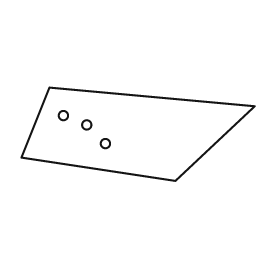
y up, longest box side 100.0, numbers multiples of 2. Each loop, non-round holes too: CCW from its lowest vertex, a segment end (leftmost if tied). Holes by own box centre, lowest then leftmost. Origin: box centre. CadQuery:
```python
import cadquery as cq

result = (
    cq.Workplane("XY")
    .moveTo(16.0, -20.0)
    .lineTo(50.0, 12.0)
    .lineTo(-38.0, 20.0)
    .lineTo(-50.0, -10.0)
    .close()
    .moveTo(-14.0, -4.0)
    .circle(2.0)
    .moveTo(-22.0, 4.0)
    .circle(2.0)
    .moveTo(-32.0, 8.0)
    .circle(2.0)
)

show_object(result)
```